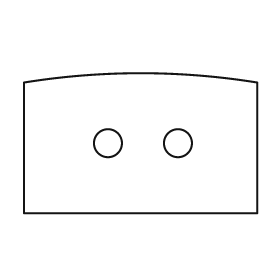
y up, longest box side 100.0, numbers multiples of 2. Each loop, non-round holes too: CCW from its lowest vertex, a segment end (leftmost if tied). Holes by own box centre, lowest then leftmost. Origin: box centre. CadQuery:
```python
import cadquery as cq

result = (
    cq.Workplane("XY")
    .moveTo(-50.0, -30.0)
    .lineTo(50.0, -30.0)
    .lineTo(50.0, 26.0)
    .threePointArc((0.0, 30.0), (-50.0, 26.0))
    .close()
    .moveTo(-14.0, 0.0)
    .circle(6.0)
    .moveTo(16.0, 0.0)
    .circle(6.0)
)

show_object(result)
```